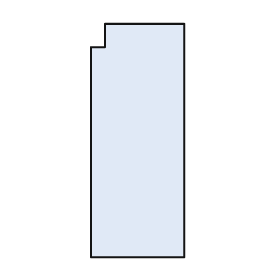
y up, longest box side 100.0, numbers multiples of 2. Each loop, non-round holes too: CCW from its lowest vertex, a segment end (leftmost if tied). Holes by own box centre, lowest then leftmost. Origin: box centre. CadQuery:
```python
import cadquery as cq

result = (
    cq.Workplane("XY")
    .moveTo(-20.0, -50.0)
    .lineTo(20.0, -50.0)
    .lineTo(20.0, 50.0)
    .lineTo(-14.0, 50.0)
    .lineTo(-14.0, 40.0)
    .lineTo(-20.0, 40.0)
    .close()
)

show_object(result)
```